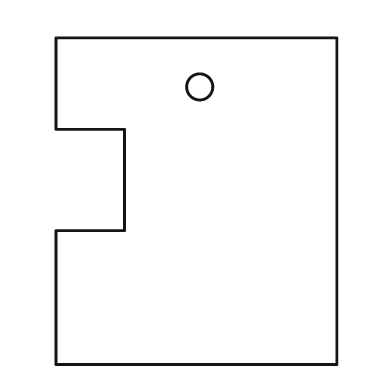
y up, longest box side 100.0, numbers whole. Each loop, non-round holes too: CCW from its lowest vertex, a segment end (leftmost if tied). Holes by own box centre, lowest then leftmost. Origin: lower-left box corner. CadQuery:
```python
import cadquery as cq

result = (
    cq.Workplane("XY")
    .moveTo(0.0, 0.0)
    .lineTo(86.0, 0.0)
    .lineTo(86.0, 100.0)
    .lineTo(0.0, 100.0)
    .lineTo(0.0, 72.0)
    .lineTo(21.0, 72.0)
    .lineTo(21.0, 41.0)
    .lineTo(0.0, 41.0)
    .close()
    .moveTo(44.0, 85.0)
    .circle(4.0)
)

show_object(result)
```